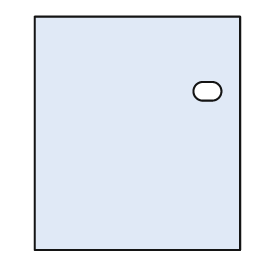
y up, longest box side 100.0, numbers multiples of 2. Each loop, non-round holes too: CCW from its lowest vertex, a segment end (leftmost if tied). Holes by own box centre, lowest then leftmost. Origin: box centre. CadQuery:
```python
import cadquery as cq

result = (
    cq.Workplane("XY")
    .moveTo(-44.0, -50.0)
    .lineTo(44.0, -50.0)
    .lineTo(44.0, 50.0)
    .lineTo(-44.0, 50.0)
    .close()
    .moveTo(28.0, 14.0)
    .lineTo(32.0, 14.0)
    .threePointArc((36.0, 18.0), (32.0, 22.0))
    .lineTo(28.0, 22.0)
    .threePointArc((24.0, 18.0), (28.0, 14.0))
    .close()
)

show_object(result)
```